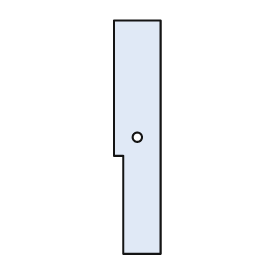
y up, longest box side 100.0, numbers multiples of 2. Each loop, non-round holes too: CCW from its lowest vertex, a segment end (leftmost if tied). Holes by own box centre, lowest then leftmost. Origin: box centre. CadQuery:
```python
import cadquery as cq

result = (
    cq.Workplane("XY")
    .moveTo(-6.0, -50.0)
    .lineTo(10.0, -50.0)
    .lineTo(10.0, 50.0)
    .lineTo(-10.0, 50.0)
    .lineTo(-10.0, -8.0)
    .lineTo(-6.0, -8.0)
    .close()
    .moveTo(0.0, 0.0)
    .circle(2.0)
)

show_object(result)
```